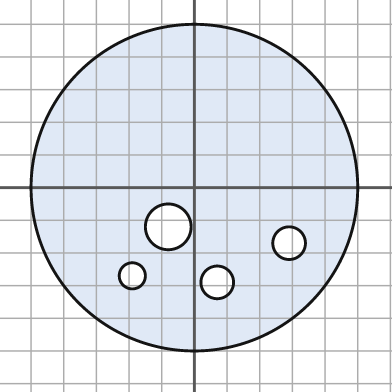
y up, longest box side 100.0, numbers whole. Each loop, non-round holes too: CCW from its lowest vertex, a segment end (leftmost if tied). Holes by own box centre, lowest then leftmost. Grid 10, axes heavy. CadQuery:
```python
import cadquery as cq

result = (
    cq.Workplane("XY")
    .moveTo(0.0, 0.0)
    .circle(50.0)
    .moveTo(7.0, -29.0)
    .circle(5.0)
    .moveTo(-19.0, -27.0)
    .circle(4.0)
    .moveTo(29.0, -17.0)
    .circle(5.0)
    .moveTo(-8.0, -12.0)
    .circle(7.0)
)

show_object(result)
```